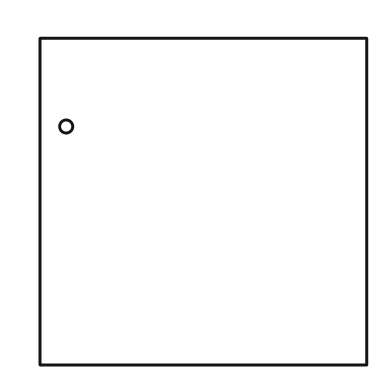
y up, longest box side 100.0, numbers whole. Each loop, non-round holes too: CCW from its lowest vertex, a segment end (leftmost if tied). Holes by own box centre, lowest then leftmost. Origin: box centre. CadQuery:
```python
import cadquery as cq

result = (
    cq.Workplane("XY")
    .moveTo(-50.0, -50.0)
    .lineTo(50.0, -50.0)
    .lineTo(50.0, 50.0)
    .lineTo(-50.0, 50.0)
    .close()
    .moveTo(-42.0, 23.0)
    .circle(2.0)
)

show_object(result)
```